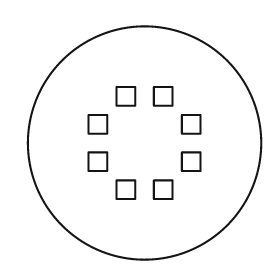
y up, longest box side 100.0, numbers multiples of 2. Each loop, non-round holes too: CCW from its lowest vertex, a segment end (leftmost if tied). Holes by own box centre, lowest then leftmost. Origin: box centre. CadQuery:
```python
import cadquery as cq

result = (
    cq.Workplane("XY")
    .moveTo(0.0, 0.0)
    .circle(50.0)
    .moveTo(-12.0, -24.0)
    .lineTo(-4.0, -24.0)
    .lineTo(-4.0, -16.0)
    .lineTo(-12.0, -16.0)
    .close()
    .moveTo(4.0, -24.0)
    .lineTo(12.0, -24.0)
    .lineTo(12.0, -16.0)
    .lineTo(4.0, -16.0)
    .close()
    .moveTo(-24.0, -12.0)
    .lineTo(-16.0, -12.0)
    .lineTo(-16.0, -4.0)
    .lineTo(-24.0, -4.0)
    .close()
    .moveTo(16.0, -12.0)
    .lineTo(24.0, -12.0)
    .lineTo(24.0, -4.0)
    .lineTo(16.0, -4.0)
    .close()
    .moveTo(-24.0, 4.0)
    .lineTo(-16.0, 4.0)
    .lineTo(-16.0, 12.0)
    .lineTo(-24.0, 12.0)
    .close()
    .moveTo(16.0, 4.0)
    .lineTo(24.0, 4.0)
    .lineTo(24.0, 12.0)
    .lineTo(16.0, 12.0)
    .close()
    .moveTo(-12.0, 16.0)
    .lineTo(-4.0, 16.0)
    .lineTo(-4.0, 24.0)
    .lineTo(-12.0, 24.0)
    .close()
    .moveTo(4.0, 16.0)
    .lineTo(12.0, 16.0)
    .lineTo(12.0, 24.0)
    .lineTo(4.0, 24.0)
    .close()
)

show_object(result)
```